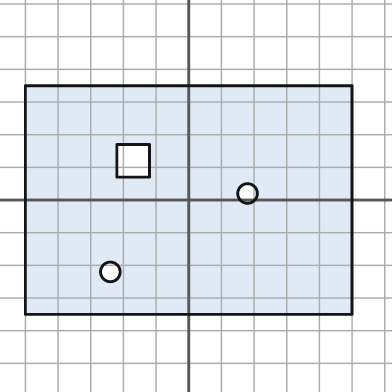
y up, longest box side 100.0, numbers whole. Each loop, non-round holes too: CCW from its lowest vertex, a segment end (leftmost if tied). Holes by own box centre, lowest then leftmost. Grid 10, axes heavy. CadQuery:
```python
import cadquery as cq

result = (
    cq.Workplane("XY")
    .moveTo(-50.0, -35.0)
    .lineTo(50.0, -35.0)
    .lineTo(50.0, 35.0)
    .lineTo(-50.0, 35.0)
    .close()
    .moveTo(-24.0, -22.0)
    .circle(3.0)
    .moveTo(18.0, 2.0)
    .circle(3.0)
    .moveTo(-22.0, 7.0)
    .lineTo(-12.0, 7.0)
    .lineTo(-12.0, 17.0)
    .lineTo(-22.0, 17.0)
    .close()
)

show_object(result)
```